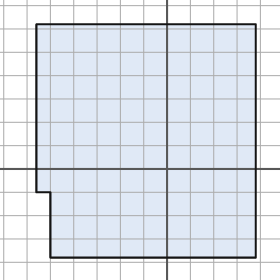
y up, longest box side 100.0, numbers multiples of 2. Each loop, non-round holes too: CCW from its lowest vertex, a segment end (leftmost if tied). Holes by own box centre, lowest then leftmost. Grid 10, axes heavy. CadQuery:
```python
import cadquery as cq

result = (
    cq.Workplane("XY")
    .moveTo(-50.0, -38.0)
    .lineTo(38.0, -38.0)
    .lineTo(38.0, 62.0)
    .lineTo(-56.0, 62.0)
    .lineTo(-56.0, -10.0)
    .lineTo(-50.0, -10.0)
    .close()
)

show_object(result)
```